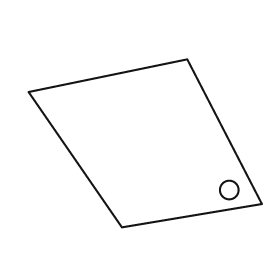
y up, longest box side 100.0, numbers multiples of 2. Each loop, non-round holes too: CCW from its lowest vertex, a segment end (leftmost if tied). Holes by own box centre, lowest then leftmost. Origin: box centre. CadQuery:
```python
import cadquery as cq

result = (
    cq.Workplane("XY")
    .moveTo(-10.0, -36.0)
    .lineTo(50.0, -26.0)
    .lineTo(18.0, 36.0)
    .lineTo(-50.0, 22.0)
    .close()
    .moveTo(36.0, -20.0)
    .circle(4.0)
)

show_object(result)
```